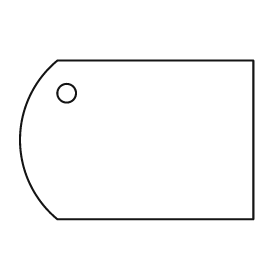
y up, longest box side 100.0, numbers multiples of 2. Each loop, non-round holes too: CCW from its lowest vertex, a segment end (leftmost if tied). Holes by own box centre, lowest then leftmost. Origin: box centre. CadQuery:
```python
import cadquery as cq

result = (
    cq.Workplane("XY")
    .moveTo(-34.0, -34.0)
    .lineTo(50.0, -34.0)
    .lineTo(50.0, 34.0)
    .lineTo(-34.0, 34.0)
    .threePointArc((-50.0, 0.0), (-34.0, -34.0))
    .close()
    .moveTo(-30.0, 20.0)
    .circle(4.0)
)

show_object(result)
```